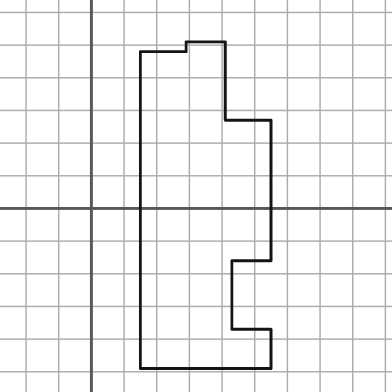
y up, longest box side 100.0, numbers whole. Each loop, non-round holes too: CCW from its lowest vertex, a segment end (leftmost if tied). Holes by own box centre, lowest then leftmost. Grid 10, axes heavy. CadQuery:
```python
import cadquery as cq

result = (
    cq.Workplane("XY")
    .moveTo(15.0, -49.0)
    .lineTo(55.0, -49.0)
    .lineTo(55.0, -37.0)
    .lineTo(43.0, -37.0)
    .lineTo(43.0, -16.0)
    .lineTo(55.0, -16.0)
    .lineTo(55.0, 27.0)
    .lineTo(41.0, 27.0)
    .lineTo(41.0, 51.0)
    .lineTo(29.0, 51.0)
    .lineTo(29.0, 48.0)
    .lineTo(15.0, 48.0)
    .close()
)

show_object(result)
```